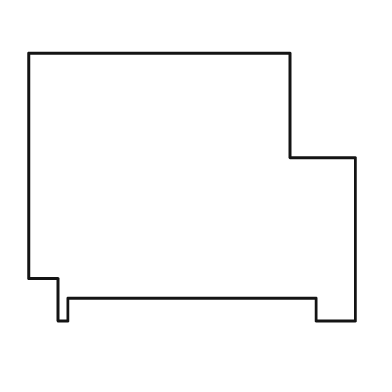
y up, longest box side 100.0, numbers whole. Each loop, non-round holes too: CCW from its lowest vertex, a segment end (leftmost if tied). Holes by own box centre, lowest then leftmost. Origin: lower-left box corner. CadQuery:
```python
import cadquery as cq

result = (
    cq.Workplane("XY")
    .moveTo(9.0, 0.0)
    .lineTo(12.0, 0.0)
    .lineTo(12.0, 7.0)
    .lineTo(88.0, 7.0)
    .lineTo(88.0, 0.0)
    .lineTo(100.0, 0.0)
    .lineTo(100.0, 50.0)
    .lineTo(80.0, 50.0)
    .lineTo(80.0, 82.0)
    .lineTo(0.0, 82.0)
    .lineTo(0.0, 13.0)
    .lineTo(9.0, 13.0)
    .close()
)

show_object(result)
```